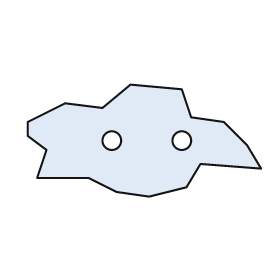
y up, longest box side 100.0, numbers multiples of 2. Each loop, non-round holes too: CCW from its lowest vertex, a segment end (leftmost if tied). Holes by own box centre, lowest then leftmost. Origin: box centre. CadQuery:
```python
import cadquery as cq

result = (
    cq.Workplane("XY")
    .moveTo(2.0, -24.0)
    .lineTo(18.0, -20.0)
    .lineTo(24.0, -10.0)
    .lineTo(50.0, -12.0)
    .lineTo(44.0, -2.0)
    .lineTo(34.0, 8.0)
    .lineTo(20.0, 10.0)
    .lineTo(16.0, 22.0)
    .lineTo(-6.0, 24.0)
    .lineTo(-18.0, 14.0)
    .lineTo(-34.0, 16.0)
    .lineTo(-50.0, 8.0)
    .lineTo(-50.0, 2.0)
    .lineTo(-42.0, -4.0)
    .lineTo(-46.0, -16.0)
    .lineTo(-24.0, -16.0)
    .lineTo(-12.0, -22.0)
    .close()
    .moveTo(-14.0, 0.0)
    .circle(4.0)
    .moveTo(16.0, 0.0)
    .circle(4.0)
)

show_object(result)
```